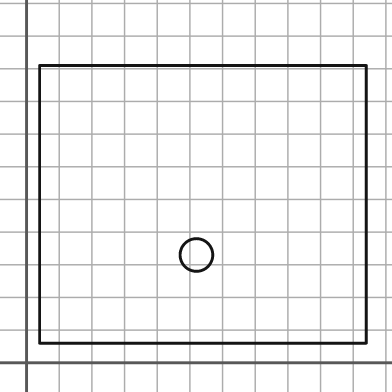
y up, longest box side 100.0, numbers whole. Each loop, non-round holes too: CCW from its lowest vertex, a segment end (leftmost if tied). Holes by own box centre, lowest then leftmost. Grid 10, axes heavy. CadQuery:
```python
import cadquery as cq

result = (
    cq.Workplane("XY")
    .moveTo(4.0, 6.0)
    .lineTo(104.0, 6.0)
    .lineTo(104.0, 91.0)
    .lineTo(4.0, 91.0)
    .close()
    .moveTo(52.0, 33.0)
    .circle(5.0)
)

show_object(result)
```